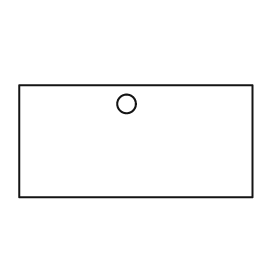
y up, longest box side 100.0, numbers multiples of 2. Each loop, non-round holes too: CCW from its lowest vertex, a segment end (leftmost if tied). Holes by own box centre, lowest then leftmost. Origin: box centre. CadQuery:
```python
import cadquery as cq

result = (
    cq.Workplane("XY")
    .moveTo(-50.0, -24.0)
    .lineTo(50.0, -24.0)
    .lineTo(50.0, 24.0)
    .lineTo(-50.0, 24.0)
    .close()
    .moveTo(-4.0, 16.0)
    .circle(4.0)
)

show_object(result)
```